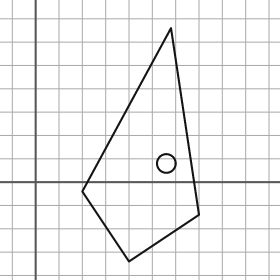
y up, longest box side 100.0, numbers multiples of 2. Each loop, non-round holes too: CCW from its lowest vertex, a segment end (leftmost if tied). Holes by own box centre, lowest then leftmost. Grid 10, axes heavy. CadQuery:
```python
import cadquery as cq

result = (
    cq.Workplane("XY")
    .moveTo(40.0, -34.0)
    .lineTo(70.0, -14.0)
    .lineTo(58.0, 66.0)
    .lineTo(20.0, -4.0)
    .close()
    .moveTo(56.0, 8.0)
    .circle(4.0)
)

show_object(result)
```